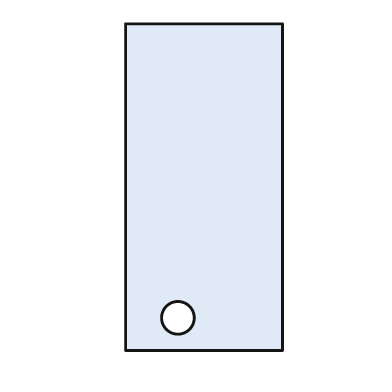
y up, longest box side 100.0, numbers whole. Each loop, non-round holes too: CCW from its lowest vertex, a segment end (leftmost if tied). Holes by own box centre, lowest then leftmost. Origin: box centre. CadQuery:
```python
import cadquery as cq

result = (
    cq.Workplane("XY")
    .moveTo(-24.0, -50.0)
    .lineTo(24.0, -50.0)
    .lineTo(24.0, 50.0)
    .lineTo(-24.0, 50.0)
    .close()
    .moveTo(-8.0, -40.0)
    .circle(5.0)
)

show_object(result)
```